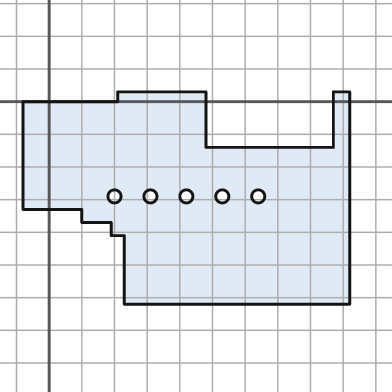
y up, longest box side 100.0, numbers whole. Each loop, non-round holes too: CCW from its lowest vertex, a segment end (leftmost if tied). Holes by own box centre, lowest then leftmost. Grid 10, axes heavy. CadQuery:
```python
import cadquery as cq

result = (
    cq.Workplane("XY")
    .moveTo(23.0, -62.0)
    .lineTo(92.0, -62.0)
    .lineTo(92.0, 3.0)
    .lineTo(87.0, 3.0)
    .lineTo(87.0, -14.0)
    .lineTo(48.0, -14.0)
    .lineTo(48.0, 3.0)
    .lineTo(21.0, 3.0)
    .lineTo(21.0, 0.0)
    .lineTo(-8.0, 0.0)
    .lineTo(-8.0, -33.0)
    .lineTo(10.0, -33.0)
    .lineTo(10.0, -37.0)
    .lineTo(19.0, -37.0)
    .lineTo(19.0, -41.0)
    .lineTo(23.0, -41.0)
    .close()
    .moveTo(20.0, -29.0)
    .circle(2.0)
    .moveTo(31.0, -29.0)
    .circle(2.0)
    .moveTo(42.0, -29.0)
    .circle(2.0)
    .moveTo(53.0, -29.0)
    .circle(2.0)
    .moveTo(64.0, -29.0)
    .circle(2.0)
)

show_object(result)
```